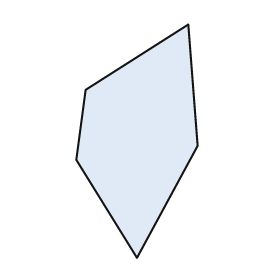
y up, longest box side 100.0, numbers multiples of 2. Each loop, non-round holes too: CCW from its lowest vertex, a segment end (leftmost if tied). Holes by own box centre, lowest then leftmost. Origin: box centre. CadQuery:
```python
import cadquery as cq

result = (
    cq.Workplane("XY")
    .moveTo(0.0, -50.0)
    .lineTo(26.0, -2.0)
    .lineTo(22.0, 50.0)
    .lineTo(-22.0, 22.0)
    .lineTo(-26.0, -8.0)
    .close()
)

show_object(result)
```